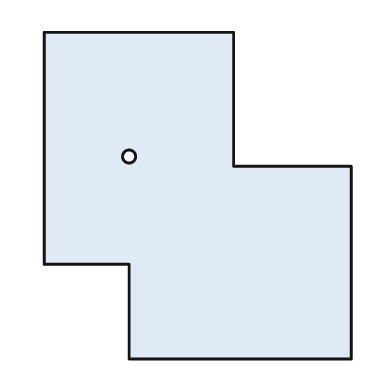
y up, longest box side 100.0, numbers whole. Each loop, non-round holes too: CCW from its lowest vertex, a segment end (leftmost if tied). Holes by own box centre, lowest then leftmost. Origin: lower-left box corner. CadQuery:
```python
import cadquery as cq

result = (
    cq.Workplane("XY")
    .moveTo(26.0, 0.0)
    .lineTo(94.0, 0.0)
    .lineTo(94.0, 59.0)
    .lineTo(58.0, 59.0)
    .lineTo(58.0, 100.0)
    .lineTo(0.0, 100.0)
    .lineTo(0.0, 29.0)
    .lineTo(26.0, 29.0)
    .close()
    .moveTo(26.0, 62.0)
    .circle(2.0)
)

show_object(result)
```